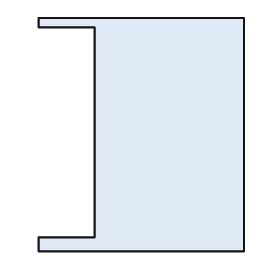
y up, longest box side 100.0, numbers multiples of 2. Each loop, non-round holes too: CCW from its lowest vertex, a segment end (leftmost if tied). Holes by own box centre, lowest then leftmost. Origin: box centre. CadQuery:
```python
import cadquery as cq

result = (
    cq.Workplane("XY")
    .moveTo(-44.0, -50.0)
    .lineTo(44.0, -50.0)
    .lineTo(44.0, 50.0)
    .lineTo(-44.0, 50.0)
    .lineTo(-44.0, 46.0)
    .lineTo(-20.0, 46.0)
    .lineTo(-20.0, -44.0)
    .lineTo(-44.0, -44.0)
    .close()
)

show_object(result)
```